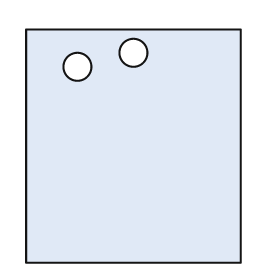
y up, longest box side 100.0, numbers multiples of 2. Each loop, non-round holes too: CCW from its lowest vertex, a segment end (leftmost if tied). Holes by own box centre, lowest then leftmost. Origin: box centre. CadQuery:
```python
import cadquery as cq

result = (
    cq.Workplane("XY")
    .moveTo(-46.0, -50.0)
    .lineTo(46.0, -50.0)
    .lineTo(46.0, 50.0)
    .lineTo(-46.0, 50.0)
    .close()
    .moveTo(-24.0, 34.0)
    .circle(6.0)
    .moveTo(0.0, 40.0)
    .circle(6.0)
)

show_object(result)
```